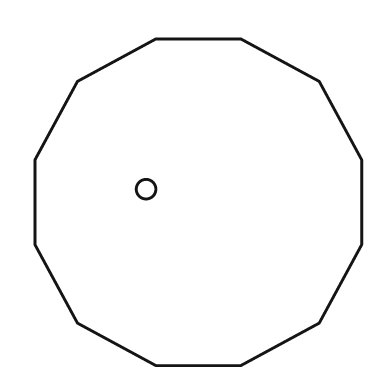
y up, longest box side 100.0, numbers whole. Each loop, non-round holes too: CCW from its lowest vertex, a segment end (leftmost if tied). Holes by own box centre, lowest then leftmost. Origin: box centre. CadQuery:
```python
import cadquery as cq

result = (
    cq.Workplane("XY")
    .moveTo(-13.0, -50.0)
    .lineTo(13.0, -50.0)
    .lineTo(37.0, -37.0)
    .lineTo(50.0, -13.0)
    .lineTo(50.0, 13.0)
    .lineTo(37.0, 37.0)
    .lineTo(13.0, 50.0)
    .lineTo(-13.0, 50.0)
    .lineTo(-37.0, 37.0)
    .lineTo(-50.0, 13.0)
    .lineTo(-50.0, -13.0)
    .lineTo(-37.0, -37.0)
    .close()
    .moveTo(-16.0, 4.0)
    .circle(3.0)
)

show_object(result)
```